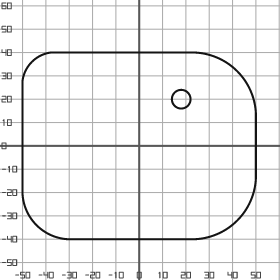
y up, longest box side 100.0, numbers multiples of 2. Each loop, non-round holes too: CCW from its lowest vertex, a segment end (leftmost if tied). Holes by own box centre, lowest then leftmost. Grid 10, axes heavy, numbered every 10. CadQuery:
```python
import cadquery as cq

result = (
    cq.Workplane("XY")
    .moveTo(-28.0, -40.0)
    .lineTo(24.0, -40.0)
    .threePointArc((42.0, -32.0), (50.0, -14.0))
    .lineTo(50.0, 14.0)
    .threePointArc((42.0, 32.0), (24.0, 40.0))
    .lineTo(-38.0, 40.0)
    .threePointArc((-46.0, 36.0), (-50.0, 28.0))
    .lineTo(-50.0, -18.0)
    .threePointArc((-44.0, -34.0), (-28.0, -40.0))
    .close()
    .moveTo(18.0, 20.0)
    .circle(4.0)
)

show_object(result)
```